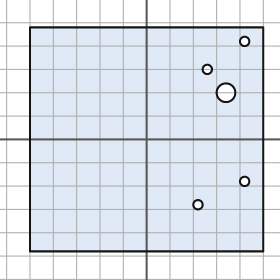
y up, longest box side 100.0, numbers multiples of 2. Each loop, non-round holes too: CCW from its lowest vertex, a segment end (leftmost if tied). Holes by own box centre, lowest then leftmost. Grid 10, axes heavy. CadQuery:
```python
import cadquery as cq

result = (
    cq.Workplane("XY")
    .moveTo(-50.0, -48.0)
    .lineTo(50.0, -48.0)
    .lineTo(50.0, 48.0)
    .lineTo(-50.0, 48.0)
    .close()
    .moveTo(22.0, -28.0)
    .circle(2.0)
    .moveTo(42.0, -18.0)
    .circle(2.0)
    .moveTo(34.0, 20.0)
    .circle(4.0)
    .moveTo(26.0, 30.0)
    .circle(2.0)
    .moveTo(42.0, 42.0)
    .circle(2.0)
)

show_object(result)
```